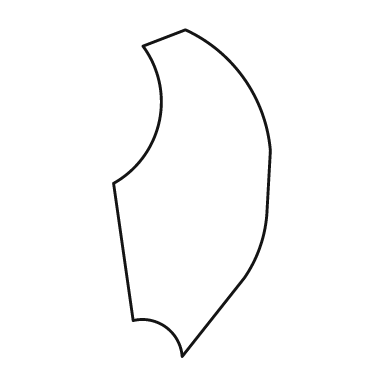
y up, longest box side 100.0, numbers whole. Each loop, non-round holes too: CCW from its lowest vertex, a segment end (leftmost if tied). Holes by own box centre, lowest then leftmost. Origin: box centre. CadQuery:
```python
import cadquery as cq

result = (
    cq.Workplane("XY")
    .moveTo(-3.0, -50.0)
    .lineTo(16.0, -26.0)
    .threePointArc((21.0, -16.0), (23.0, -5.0))
    .lineTo(24.0, 13.0)
    .threePointArc((16.0, 35.0), (-2.0, 50.0))
    .lineTo(-15.0, 45.0)
    .threePointArc((-10.0, 22.0), (-24.0, 3.0))
    .lineTo(-18.0, -39.0)
    .threePointArc((-8.0, -41.0), (-3.0, -50.0))
    .close()
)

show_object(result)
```